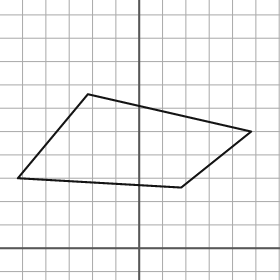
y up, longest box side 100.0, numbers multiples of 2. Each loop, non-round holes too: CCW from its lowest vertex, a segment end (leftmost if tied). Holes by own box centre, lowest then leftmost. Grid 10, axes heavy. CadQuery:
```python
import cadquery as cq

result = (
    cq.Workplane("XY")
    .moveTo(18.0, 26.0)
    .lineTo(48.0, 50.0)
    .lineTo(-22.0, 66.0)
    .lineTo(-52.0, 30.0)
    .close()
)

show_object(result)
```